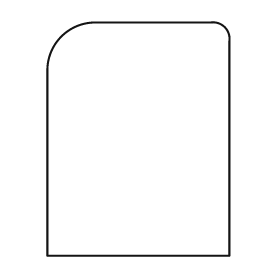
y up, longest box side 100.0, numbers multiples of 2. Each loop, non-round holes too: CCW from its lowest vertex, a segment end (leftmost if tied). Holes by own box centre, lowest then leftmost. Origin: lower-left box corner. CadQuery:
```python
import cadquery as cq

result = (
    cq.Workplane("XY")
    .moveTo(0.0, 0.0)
    .lineTo(78.0, 0.0)
    .lineTo(78.0, 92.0)
    .threePointArc((76.0, 98.0), (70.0, 100.0))
    .lineTo(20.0, 100.0)
    .threePointArc((6.0, 94.0), (0.0, 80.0))
    .close()
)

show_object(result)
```